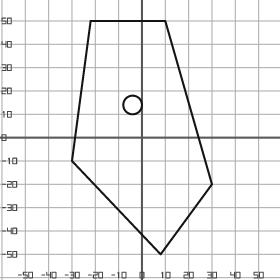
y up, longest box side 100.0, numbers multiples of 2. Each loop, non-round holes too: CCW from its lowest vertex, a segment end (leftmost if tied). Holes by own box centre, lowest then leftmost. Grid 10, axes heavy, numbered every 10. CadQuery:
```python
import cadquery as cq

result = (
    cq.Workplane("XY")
    .moveTo(8.0, -50.0)
    .lineTo(30.0, -20.0)
    .lineTo(10.0, 50.0)
    .lineTo(-22.0, 50.0)
    .lineTo(-30.0, -10.0)
    .close()
    .moveTo(-4.0, 14.0)
    .circle(4.0)
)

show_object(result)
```